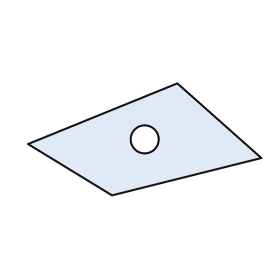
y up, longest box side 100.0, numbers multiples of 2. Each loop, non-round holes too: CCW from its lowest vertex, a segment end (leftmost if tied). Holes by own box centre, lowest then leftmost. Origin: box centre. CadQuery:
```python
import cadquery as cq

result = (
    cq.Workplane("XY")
    .moveTo(-14.0, -24.0)
    .lineTo(50.0, -8.0)
    .lineTo(14.0, 24.0)
    .lineTo(-50.0, -2.0)
    .close()
    .moveTo(0.0, 0.0)
    .circle(6.0)
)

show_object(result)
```